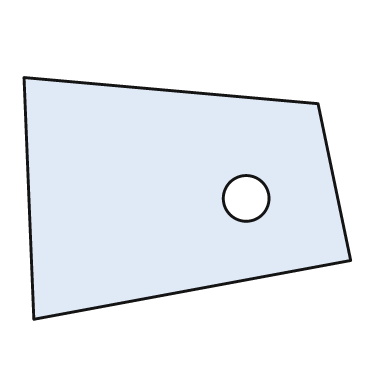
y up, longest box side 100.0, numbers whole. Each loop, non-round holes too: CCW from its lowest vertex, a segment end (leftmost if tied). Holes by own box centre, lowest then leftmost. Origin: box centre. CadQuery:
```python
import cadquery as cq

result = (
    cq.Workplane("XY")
    .moveTo(-47.0, -37.0)
    .lineTo(50.0, -19.0)
    .lineTo(40.0, 29.0)
    .lineTo(-50.0, 37.0)
    .close()
    .moveTo(18.0, 0.0)
    .circle(7.0)
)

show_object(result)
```